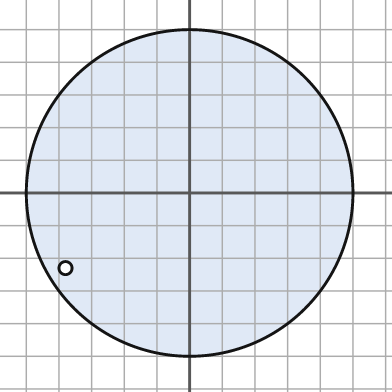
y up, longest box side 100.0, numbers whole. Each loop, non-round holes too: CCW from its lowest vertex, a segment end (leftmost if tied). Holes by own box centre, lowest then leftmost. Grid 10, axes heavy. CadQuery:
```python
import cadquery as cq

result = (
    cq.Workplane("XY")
    .moveTo(0.0, 0.0)
    .circle(50.0)
    .moveTo(-38.0, -23.0)
    .circle(2.0)
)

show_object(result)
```